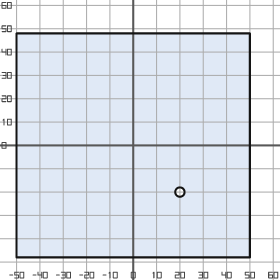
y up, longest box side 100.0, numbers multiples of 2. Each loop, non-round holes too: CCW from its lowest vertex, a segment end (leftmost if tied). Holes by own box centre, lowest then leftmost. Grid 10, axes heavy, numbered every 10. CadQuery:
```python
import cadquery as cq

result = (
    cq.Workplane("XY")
    .moveTo(-50.0, -48.0)
    .lineTo(50.0, -48.0)
    .lineTo(50.0, 48.0)
    .lineTo(-50.0, 48.0)
    .close()
    .moveTo(20.0, -20.0)
    .circle(2.0)
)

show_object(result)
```